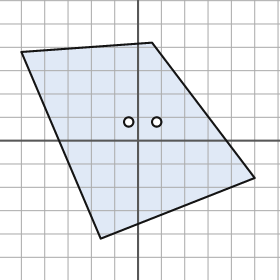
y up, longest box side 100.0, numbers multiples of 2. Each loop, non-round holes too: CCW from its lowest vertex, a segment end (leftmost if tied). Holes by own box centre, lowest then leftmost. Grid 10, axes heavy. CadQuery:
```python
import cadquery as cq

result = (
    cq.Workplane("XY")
    .moveTo(-16.0, -42.0)
    .lineTo(50.0, -16.0)
    .lineTo(6.0, 42.0)
    .lineTo(-50.0, 38.0)
    .close()
    .moveTo(-4.0, 8.0)
    .circle(2.0)
    .moveTo(8.0, 8.0)
    .circle(2.0)
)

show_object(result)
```